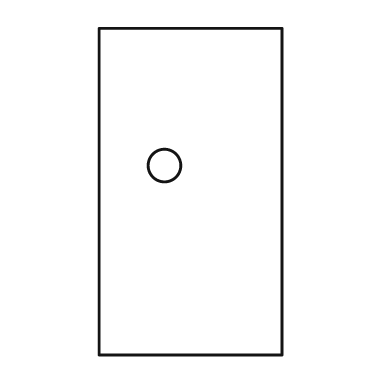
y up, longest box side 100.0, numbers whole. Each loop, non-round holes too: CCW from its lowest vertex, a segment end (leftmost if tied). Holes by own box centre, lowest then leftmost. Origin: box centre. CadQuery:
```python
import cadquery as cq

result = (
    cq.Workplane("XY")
    .moveTo(-28.0, -50.0)
    .lineTo(28.0, -50.0)
    .lineTo(28.0, 50.0)
    .lineTo(-28.0, 50.0)
    .close()
    .moveTo(-8.0, 8.0)
    .circle(5.0)
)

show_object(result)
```